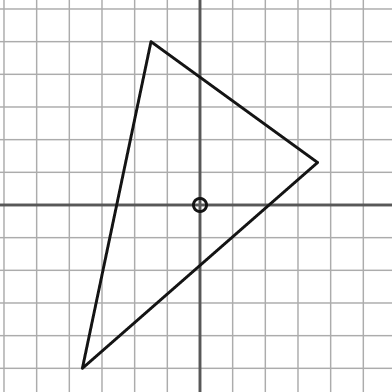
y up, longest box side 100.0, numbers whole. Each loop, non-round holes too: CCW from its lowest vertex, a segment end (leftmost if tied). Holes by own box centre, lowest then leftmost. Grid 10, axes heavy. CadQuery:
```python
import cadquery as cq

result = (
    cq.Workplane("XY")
    .moveTo(-36.0, -50.0)
    .lineTo(36.0, 13.0)
    .lineTo(-15.0, 50.0)
    .close()
    .moveTo(0.0, 0.0)
    .circle(2.0)
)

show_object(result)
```